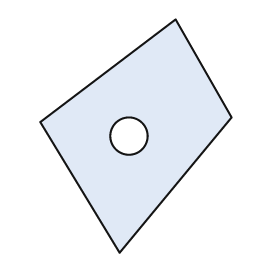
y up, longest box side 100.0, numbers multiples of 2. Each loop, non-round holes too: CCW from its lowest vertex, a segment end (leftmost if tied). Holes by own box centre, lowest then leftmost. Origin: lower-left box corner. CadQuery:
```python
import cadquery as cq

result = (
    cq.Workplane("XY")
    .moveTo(34.0, 0.0)
    .lineTo(82.0, 58.0)
    .lineTo(58.0, 100.0)
    .lineTo(0.0, 56.0)
    .close()
    .moveTo(38.0, 50.0)
    .circle(8.0)
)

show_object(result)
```